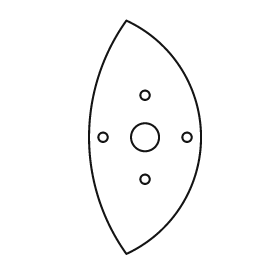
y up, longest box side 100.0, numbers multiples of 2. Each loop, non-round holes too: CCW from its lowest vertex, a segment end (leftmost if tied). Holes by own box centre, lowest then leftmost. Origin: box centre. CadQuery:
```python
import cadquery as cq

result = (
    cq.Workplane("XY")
    .moveTo(-8.0, -50.0)
    .threePointArc((24.0, 0.0), (-8.0, 50.0))
    .threePointArc((-24.0, 0.0), (-8.0, -50.0))
    .close()
    .moveTo(0.0, -18.0)
    .circle(2.0)
    .moveTo(-18.0, 0.0)
    .circle(2.0)
    .moveTo(0.0, 0.0)
    .circle(6.0)
    .moveTo(18.0, 0.0)
    .circle(2.0)
    .moveTo(0.0, 18.0)
    .circle(2.0)
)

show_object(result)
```